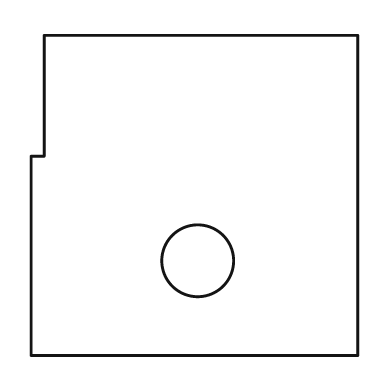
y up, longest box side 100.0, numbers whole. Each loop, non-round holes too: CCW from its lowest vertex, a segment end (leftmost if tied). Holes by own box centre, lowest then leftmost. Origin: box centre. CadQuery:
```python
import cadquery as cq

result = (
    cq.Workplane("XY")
    .moveTo(-50.0, -49.0)
    .lineTo(50.0, -49.0)
    .lineTo(50.0, 49.0)
    .lineTo(-46.0, 49.0)
    .lineTo(-46.0, 12.0)
    .lineTo(-50.0, 12.0)
    .close()
    .moveTo(1.0, -20.0)
    .circle(11.0)
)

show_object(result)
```